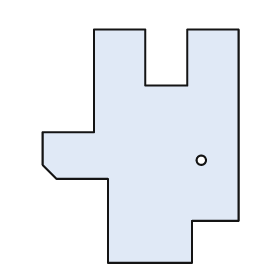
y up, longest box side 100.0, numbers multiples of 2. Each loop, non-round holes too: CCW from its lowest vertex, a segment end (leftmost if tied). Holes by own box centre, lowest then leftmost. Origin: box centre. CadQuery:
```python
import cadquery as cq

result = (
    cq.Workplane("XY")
    .moveTo(-14.0, -50.0)
    .lineTo(22.0, -50.0)
    .lineTo(22.0, -32.0)
    .lineTo(42.0, -32.0)
    .lineTo(42.0, 50.0)
    .lineTo(20.0, 50.0)
    .lineTo(20.0, 26.0)
    .lineTo(2.0, 26.0)
    .lineTo(2.0, 50.0)
    .lineTo(-20.0, 50.0)
    .lineTo(-20.0, 6.0)
    .lineTo(-42.0, 6.0)
    .lineTo(-42.0, -8.0)
    .lineTo(-36.0, -14.0)
    .lineTo(-14.0, -14.0)
    .close()
    .moveTo(26.0, -6.0)
    .circle(2.0)
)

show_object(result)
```